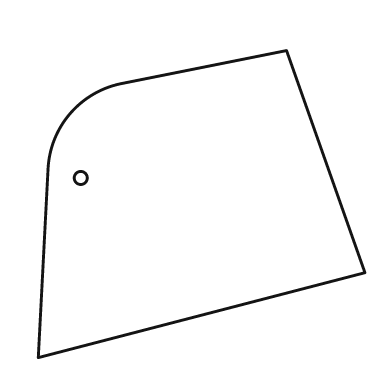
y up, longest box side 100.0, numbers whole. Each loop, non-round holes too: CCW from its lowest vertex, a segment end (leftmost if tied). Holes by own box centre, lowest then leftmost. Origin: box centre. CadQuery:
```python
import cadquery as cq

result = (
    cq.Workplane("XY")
    .moveTo(-50.0, -47.0)
    .lineTo(50.0, -21.0)
    .lineTo(26.0, 47.0)
    .lineTo(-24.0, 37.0)
    .threePointArc((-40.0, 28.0), (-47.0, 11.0))
    .close()
    .moveTo(-37.0, 8.0)
    .circle(2.0)
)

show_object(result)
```